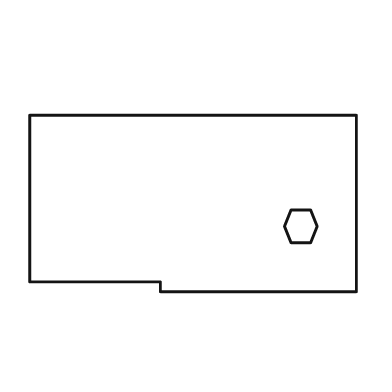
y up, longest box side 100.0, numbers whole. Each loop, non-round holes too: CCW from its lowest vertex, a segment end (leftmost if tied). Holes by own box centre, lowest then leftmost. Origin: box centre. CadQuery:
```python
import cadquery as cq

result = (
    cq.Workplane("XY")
    .moveTo(-10.0, -27.0)
    .lineTo(50.0, -27.0)
    .lineTo(50.0, 27.0)
    .lineTo(-50.0, 27.0)
    .lineTo(-50.0, -24.0)
    .lineTo(-10.0, -24.0)
    .close()
    .moveTo(30.0, -12.0)
    .lineTo(36.0, -12.0)
    .lineTo(38.0, -7.0)
    .lineTo(36.0, -2.0)
    .lineTo(30.0, -2.0)
    .lineTo(28.0, -7.0)
    .close()
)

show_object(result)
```